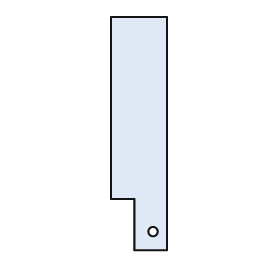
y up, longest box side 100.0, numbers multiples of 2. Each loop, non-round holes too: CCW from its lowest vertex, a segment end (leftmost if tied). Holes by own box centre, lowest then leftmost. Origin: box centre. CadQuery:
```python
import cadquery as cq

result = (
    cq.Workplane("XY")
    .moveTo(-2.0, -50.0)
    .lineTo(12.0, -50.0)
    .lineTo(12.0, 50.0)
    .lineTo(-12.0, 50.0)
    .lineTo(-12.0, -28.0)
    .lineTo(-2.0, -28.0)
    .close()
    .moveTo(6.0, -42.0)
    .circle(2.0)
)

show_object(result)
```